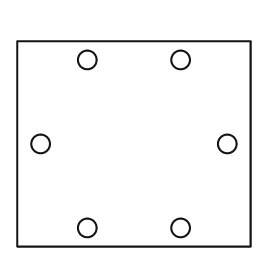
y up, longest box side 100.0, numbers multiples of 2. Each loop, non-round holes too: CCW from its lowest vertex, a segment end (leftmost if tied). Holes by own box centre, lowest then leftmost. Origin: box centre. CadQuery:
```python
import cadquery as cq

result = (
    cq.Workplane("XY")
    .moveTo(-50.0, -44.0)
    .lineTo(50.0, -44.0)
    .lineTo(50.0, 44.0)
    .lineTo(-50.0, 44.0)
    .close()
    .moveTo(-20.0, -36.0)
    .circle(4.0)
    .moveTo(20.0, -36.0)
    .circle(4.0)
    .moveTo(-40.0, 0.0)
    .circle(4.0)
    .moveTo(40.0, 0.0)
    .circle(4.0)
    .moveTo(-20.0, 36.0)
    .circle(4.0)
    .moveTo(20.0, 36.0)
    .circle(4.0)
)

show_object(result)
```